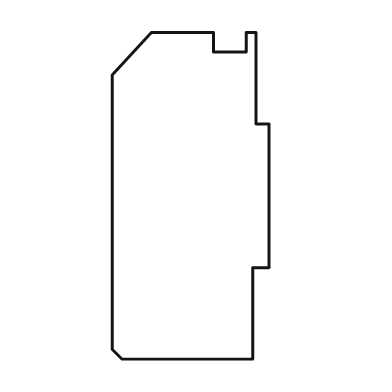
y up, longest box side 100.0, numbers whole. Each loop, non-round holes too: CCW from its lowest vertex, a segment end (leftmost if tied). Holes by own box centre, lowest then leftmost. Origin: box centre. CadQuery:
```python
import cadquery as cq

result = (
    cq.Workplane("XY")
    .moveTo(-21.0, -50.0)
    .lineTo(19.0, -50.0)
    .lineTo(19.0, -22.0)
    .lineTo(24.0, -22.0)
    .lineTo(24.0, 22.0)
    .lineTo(20.0, 22.0)
    .lineTo(20.0, 50.0)
    .lineTo(17.0, 50.0)
    .lineTo(17.0, 44.0)
    .lineTo(7.0, 44.0)
    .lineTo(7.0, 50.0)
    .lineTo(-12.0, 50.0)
    .lineTo(-24.0, 37.0)
    .lineTo(-24.0, -47.0)
    .close()
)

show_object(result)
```